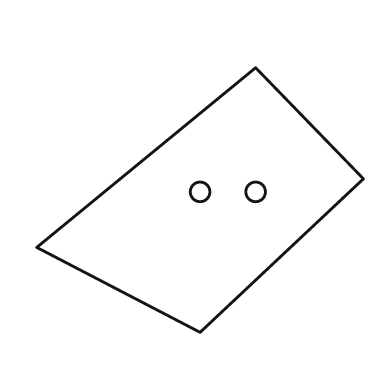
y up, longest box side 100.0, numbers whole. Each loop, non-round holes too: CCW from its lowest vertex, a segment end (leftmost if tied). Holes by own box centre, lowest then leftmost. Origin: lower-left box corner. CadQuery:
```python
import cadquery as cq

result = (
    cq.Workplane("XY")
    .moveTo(50.0, 0.0)
    .lineTo(100.0, 47.0)
    .lineTo(67.0, 81.0)
    .lineTo(0.0, 26.0)
    .close()
    .moveTo(50.0, 43.0)
    .circle(3.0)
    .moveTo(67.0, 43.0)
    .circle(3.0)
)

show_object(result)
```